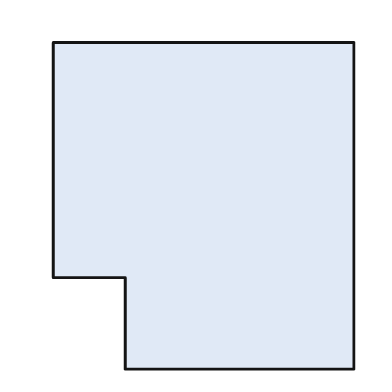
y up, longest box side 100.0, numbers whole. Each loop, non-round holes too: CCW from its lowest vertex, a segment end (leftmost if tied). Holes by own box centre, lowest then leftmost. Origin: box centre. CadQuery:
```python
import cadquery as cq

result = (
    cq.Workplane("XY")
    .moveTo(-24.0, -50.0)
    .lineTo(46.0, -50.0)
    .lineTo(46.0, 50.0)
    .lineTo(-46.0, 50.0)
    .lineTo(-46.0, -22.0)
    .lineTo(-24.0, -22.0)
    .close()
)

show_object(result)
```